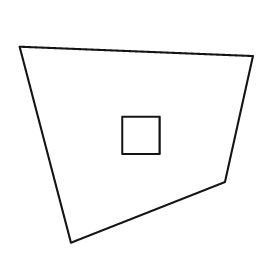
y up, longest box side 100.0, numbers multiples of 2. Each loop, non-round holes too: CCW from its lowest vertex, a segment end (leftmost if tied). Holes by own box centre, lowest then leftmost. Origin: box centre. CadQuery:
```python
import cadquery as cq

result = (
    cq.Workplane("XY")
    .moveTo(-28.0, -42.0)
    .lineTo(38.0, -16.0)
    .lineTo(50.0, 38.0)
    .lineTo(-50.0, 42.0)
    .close()
    .moveTo(-6.0, -4.0)
    .lineTo(10.0, -4.0)
    .lineTo(10.0, 12.0)
    .lineTo(-6.0, 12.0)
    .close()
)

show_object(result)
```